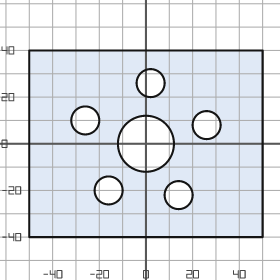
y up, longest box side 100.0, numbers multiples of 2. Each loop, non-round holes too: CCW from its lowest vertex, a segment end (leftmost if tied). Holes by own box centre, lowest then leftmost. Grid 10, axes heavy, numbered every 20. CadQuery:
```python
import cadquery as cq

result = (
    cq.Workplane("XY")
    .moveTo(-50.0, -40.0)
    .lineTo(50.0, -40.0)
    .lineTo(50.0, 40.0)
    .lineTo(-50.0, 40.0)
    .close()
    .moveTo(14.0, -22.0)
    .circle(6.0)
    .moveTo(-16.0, -20.0)
    .circle(6.0)
    .moveTo(0.0, 0.0)
    .circle(12.0)
    .moveTo(26.0, 8.0)
    .circle(6.0)
    .moveTo(-26.0, 10.0)
    .circle(6.0)
    .moveTo(2.0, 26.0)
    .circle(6.0)
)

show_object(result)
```